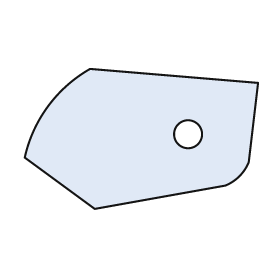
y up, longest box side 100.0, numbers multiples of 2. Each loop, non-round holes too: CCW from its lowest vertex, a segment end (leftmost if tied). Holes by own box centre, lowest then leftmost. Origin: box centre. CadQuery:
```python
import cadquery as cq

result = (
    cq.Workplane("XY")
    .moveTo(-20.0, -30.0)
    .lineTo(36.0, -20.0)
    .threePointArc((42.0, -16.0), (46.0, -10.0))
    .lineTo(50.0, 24.0)
    .lineTo(-22.0, 30.0)
    .threePointArc((-40.0, 14.0), (-50.0, -8.0))
    .close()
    .moveTo(20.0, 2.0)
    .circle(6.0)
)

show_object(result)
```